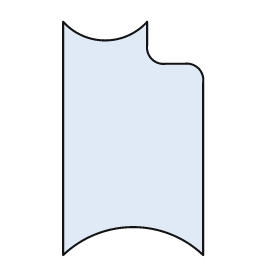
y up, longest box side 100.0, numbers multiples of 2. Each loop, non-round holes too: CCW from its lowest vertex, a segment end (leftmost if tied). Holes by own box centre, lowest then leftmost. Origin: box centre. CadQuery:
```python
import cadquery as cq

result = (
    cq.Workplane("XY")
    .moveTo(-30.0, -50.0)
    .threePointArc((0.0, -38.0), (30.0, -50.0))
    .lineTo(30.0, 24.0)
    .threePointArc((28.0, 30.0), (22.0, 32.0))
    .lineTo(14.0, 32.0)
    .threePointArc((8.0, 34.0), (6.0, 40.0))
    .lineTo(6.0, 50.0)
    .threePointArc((-12.0, 42.0), (-30.0, 50.0))
    .close()
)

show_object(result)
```